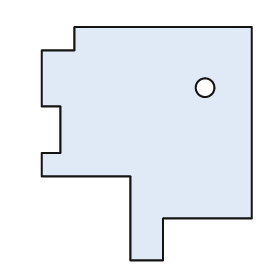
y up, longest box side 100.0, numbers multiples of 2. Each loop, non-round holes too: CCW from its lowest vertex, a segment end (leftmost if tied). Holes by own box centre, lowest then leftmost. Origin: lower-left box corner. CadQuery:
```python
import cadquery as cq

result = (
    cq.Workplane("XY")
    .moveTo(38.0, 0.0)
    .lineTo(52.0, 0.0)
    .lineTo(52.0, 18.0)
    .lineTo(90.0, 18.0)
    .lineTo(90.0, 100.0)
    .lineTo(14.0, 100.0)
    .lineTo(14.0, 90.0)
    .lineTo(0.0, 90.0)
    .lineTo(0.0, 66.0)
    .lineTo(8.0, 66.0)
    .lineTo(8.0, 46.0)
    .lineTo(0.0, 46.0)
    .lineTo(0.0, 36.0)
    .lineTo(38.0, 36.0)
    .close()
    .moveTo(70.0, 74.0)
    .circle(4.0)
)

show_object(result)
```